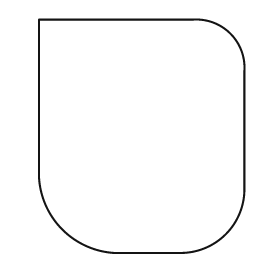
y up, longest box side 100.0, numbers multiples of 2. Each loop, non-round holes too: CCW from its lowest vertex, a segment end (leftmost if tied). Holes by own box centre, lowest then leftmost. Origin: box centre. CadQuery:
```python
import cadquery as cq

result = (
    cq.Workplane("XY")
    .moveTo(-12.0, -50.0)
    .lineTo(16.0, -50.0)
    .threePointArc((36.0, -42.0), (44.0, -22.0))
    .lineTo(44.0, 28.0)
    .threePointArc((38.0, 44.0), (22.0, 50.0))
    .lineTo(-44.0, 50.0)
    .lineTo(-44.0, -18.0)
    .threePointArc((-34.0, -40.0), (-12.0, -50.0))
    .close()
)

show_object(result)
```